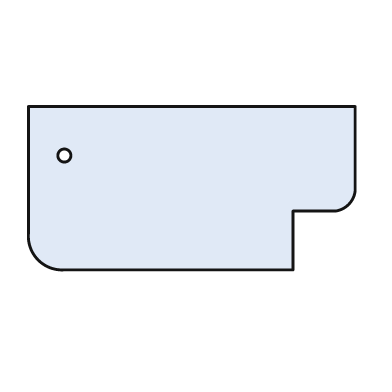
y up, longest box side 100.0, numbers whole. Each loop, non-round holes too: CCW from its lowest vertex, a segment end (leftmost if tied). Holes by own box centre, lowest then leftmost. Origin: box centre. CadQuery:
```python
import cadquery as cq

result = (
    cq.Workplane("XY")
    .moveTo(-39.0, -25.0)
    .lineTo(31.0, -25.0)
    .lineTo(31.0, -7.0)
    .lineTo(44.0, -7.0)
    .threePointArc((48.0, -5.0), (50.0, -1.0))
    .lineTo(50.0, 25.0)
    .lineTo(-50.0, 25.0)
    .lineTo(-50.0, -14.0)
    .threePointArc((-47.0, -22.0), (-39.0, -25.0))
    .close()
    .moveTo(-39.0, 10.0)
    .circle(2.0)
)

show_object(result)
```